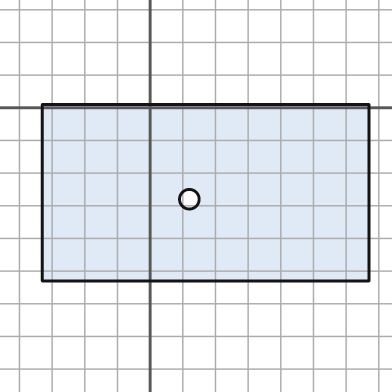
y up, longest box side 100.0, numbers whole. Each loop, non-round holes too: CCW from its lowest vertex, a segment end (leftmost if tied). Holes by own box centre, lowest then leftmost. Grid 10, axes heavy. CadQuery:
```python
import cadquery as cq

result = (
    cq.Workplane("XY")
    .moveTo(-33.0, -53.0)
    .lineTo(67.0, -53.0)
    .lineTo(67.0, 1.0)
    .lineTo(-33.0, 1.0)
    .close()
    .moveTo(12.0, -28.0)
    .circle(3.0)
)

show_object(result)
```